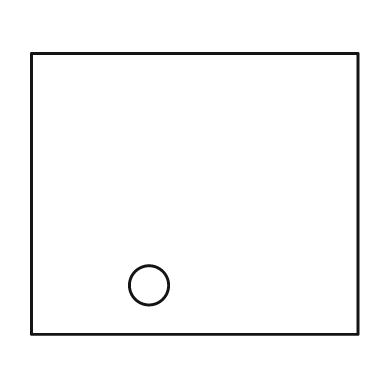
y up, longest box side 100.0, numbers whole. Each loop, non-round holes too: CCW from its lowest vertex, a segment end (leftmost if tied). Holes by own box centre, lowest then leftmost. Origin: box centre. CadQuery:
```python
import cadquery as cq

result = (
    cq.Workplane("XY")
    .moveTo(-50.0, -43.0)
    .lineTo(50.0, -43.0)
    .lineTo(50.0, 43.0)
    .lineTo(-50.0, 43.0)
    .close()
    .moveTo(-14.0, -28.0)
    .circle(6.0)
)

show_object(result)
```